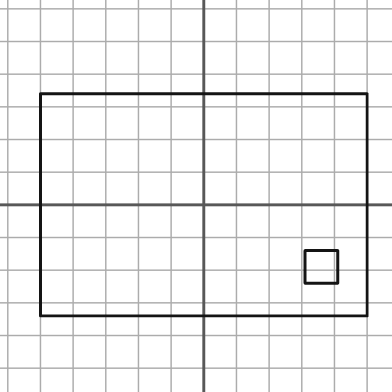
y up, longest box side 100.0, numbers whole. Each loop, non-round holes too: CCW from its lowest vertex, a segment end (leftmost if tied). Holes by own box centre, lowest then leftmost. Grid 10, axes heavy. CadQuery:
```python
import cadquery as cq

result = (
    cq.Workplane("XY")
    .moveTo(-50.0, -34.0)
    .lineTo(50.0, -34.0)
    .lineTo(50.0, 34.0)
    .lineTo(-50.0, 34.0)
    .close()
    .moveTo(31.0, -24.0)
    .lineTo(41.0, -24.0)
    .lineTo(41.0, -14.0)
    .lineTo(31.0, -14.0)
    .close()
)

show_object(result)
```